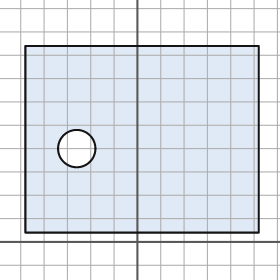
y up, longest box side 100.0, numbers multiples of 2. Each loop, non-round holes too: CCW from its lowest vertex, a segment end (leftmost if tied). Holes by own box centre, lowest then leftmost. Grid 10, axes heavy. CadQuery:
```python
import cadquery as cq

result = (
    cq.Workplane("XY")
    .moveTo(-48.0, 4.0)
    .lineTo(52.0, 4.0)
    .lineTo(52.0, 84.0)
    .lineTo(-48.0, 84.0)
    .close()
    .moveTo(-26.0, 40.0)
    .circle(8.0)
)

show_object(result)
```